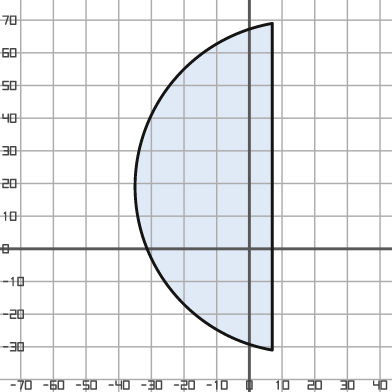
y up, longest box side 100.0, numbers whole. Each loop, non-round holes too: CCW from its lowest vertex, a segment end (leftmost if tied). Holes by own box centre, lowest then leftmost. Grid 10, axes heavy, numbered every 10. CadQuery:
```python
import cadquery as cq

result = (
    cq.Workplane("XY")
    .moveTo(7.0, -31.0)
    .lineTo(7.0, 69.0)
    .threePointArc((-35.0, 19.0), (7.0, -31.0))
    .close()
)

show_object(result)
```